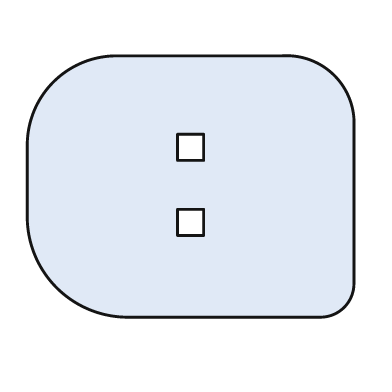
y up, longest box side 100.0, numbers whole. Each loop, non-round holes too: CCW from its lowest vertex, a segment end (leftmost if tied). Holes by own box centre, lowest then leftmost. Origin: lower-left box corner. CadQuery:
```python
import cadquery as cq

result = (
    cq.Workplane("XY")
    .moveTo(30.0, 0.0)
    .lineTo(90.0, 0.0)
    .threePointArc((97.0, 3.0), (100.0, 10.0))
    .lineTo(100.0, 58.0)
    .threePointArc((94.0, 74.0), (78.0, 80.0))
    .lineTo(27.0, 80.0)
    .threePointArc((8.0, 72.0), (0.0, 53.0))
    .lineTo(0.0, 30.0)
    .threePointArc((9.0, 9.0), (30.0, 0.0))
    .close()
    .moveTo(46.0, 25.0)
    .lineTo(54.0, 25.0)
    .lineTo(54.0, 33.0)
    .lineTo(46.0, 33.0)
    .close()
    .moveTo(46.0, 48.0)
    .lineTo(54.0, 48.0)
    .lineTo(54.0, 56.0)
    .lineTo(46.0, 56.0)
    .close()
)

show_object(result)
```